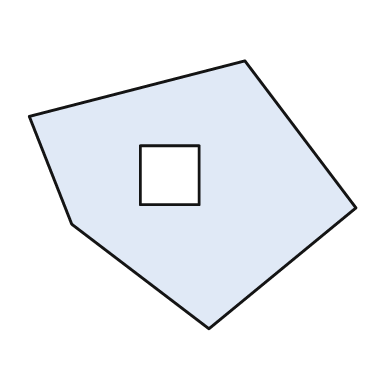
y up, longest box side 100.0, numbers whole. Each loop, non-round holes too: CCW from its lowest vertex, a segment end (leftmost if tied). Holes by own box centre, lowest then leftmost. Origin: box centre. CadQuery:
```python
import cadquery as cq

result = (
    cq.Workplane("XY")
    .moveTo(5.0, -41.0)
    .lineTo(50.0, -4.0)
    .lineTo(16.0, 41.0)
    .lineTo(-50.0, 24.0)
    .lineTo(-37.0, -9.0)
    .close()
    .moveTo(-16.0, -3.0)
    .lineTo(2.0, -3.0)
    .lineTo(2.0, 15.0)
    .lineTo(-16.0, 15.0)
    .close()
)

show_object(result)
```